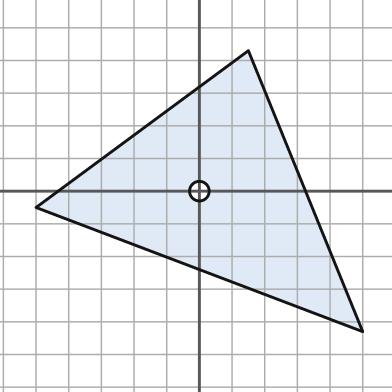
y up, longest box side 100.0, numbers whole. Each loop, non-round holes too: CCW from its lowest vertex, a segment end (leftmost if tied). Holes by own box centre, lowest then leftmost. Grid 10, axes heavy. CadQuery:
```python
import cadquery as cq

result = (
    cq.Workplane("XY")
    .moveTo(50.0, -43.0)
    .lineTo(15.0, 43.0)
    .lineTo(-50.0, -5.0)
    .close()
    .moveTo(0.0, 0.0)
    .circle(3.0)
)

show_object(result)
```